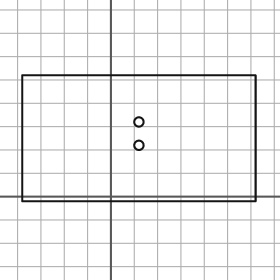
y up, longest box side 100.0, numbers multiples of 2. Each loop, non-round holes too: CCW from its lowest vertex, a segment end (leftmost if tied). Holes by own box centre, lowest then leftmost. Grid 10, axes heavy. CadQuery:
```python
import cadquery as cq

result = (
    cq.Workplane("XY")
    .moveTo(-38.0, -2.0)
    .lineTo(62.0, -2.0)
    .lineTo(62.0, 52.0)
    .lineTo(-38.0, 52.0)
    .close()
    .moveTo(12.0, 22.0)
    .circle(2.0)
    .moveTo(12.0, 32.0)
    .circle(2.0)
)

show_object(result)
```